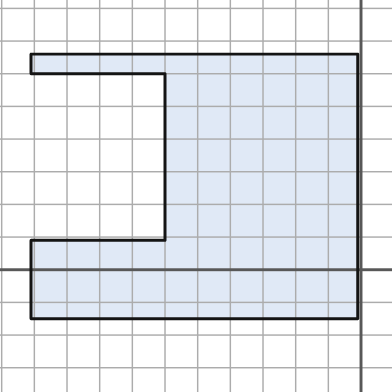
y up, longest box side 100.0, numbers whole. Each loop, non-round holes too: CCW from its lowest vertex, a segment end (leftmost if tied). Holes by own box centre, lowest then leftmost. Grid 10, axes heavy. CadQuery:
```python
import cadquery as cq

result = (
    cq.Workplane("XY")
    .moveTo(-101.0, -15.0)
    .lineTo(-1.0, -15.0)
    .lineTo(-1.0, 66.0)
    .lineTo(-101.0, 66.0)
    .lineTo(-101.0, 60.0)
    .lineTo(-60.0, 60.0)
    .lineTo(-60.0, 9.0)
    .lineTo(-101.0, 9.0)
    .close()
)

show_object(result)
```